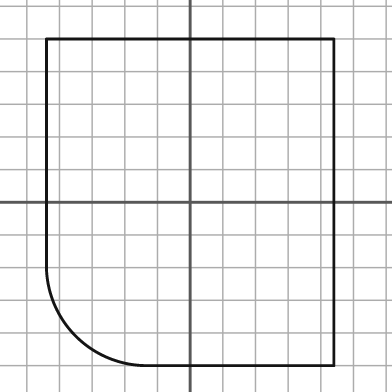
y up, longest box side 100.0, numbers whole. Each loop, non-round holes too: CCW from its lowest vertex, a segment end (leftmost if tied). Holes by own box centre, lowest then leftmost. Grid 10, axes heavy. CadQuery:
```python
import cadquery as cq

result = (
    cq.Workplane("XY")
    .moveTo(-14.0, -50.0)
    .lineTo(44.0, -50.0)
    .lineTo(44.0, 50.0)
    .lineTo(-44.0, 50.0)
    .lineTo(-44.0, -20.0)
    .threePointArc((-35.0, -41.0), (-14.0, -50.0))
    .close()
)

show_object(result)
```